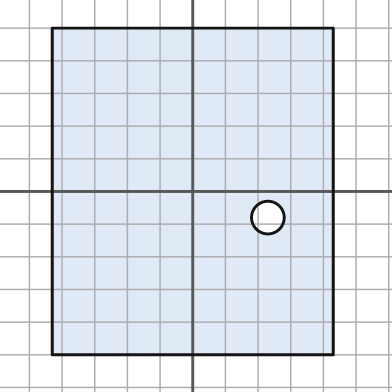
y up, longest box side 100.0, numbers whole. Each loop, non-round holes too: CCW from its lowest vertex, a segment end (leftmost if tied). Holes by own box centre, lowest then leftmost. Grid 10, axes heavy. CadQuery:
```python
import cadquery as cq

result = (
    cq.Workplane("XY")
    .moveTo(-43.0, -50.0)
    .lineTo(43.0, -50.0)
    .lineTo(43.0, 50.0)
    .lineTo(-43.0, 50.0)
    .close()
    .moveTo(23.0, -8.0)
    .circle(5.0)
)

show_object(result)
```